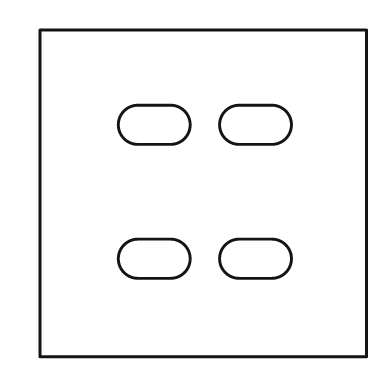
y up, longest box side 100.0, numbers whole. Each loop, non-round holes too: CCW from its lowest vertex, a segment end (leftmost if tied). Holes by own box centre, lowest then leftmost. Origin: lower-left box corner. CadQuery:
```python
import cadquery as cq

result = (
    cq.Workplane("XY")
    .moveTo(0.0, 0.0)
    .lineTo(100.0, 0.0)
    .lineTo(100.0, 100.0)
    .lineTo(0.0, 100.0)
    .close()
    .moveTo(30.0, 24.0)
    .lineTo(40.0, 24.0)
    .threePointArc((46.0, 30.0), (40.0, 36.0))
    .lineTo(30.0, 36.0)
    .threePointArc((24.0, 30.0), (30.0, 24.0))
    .close()
    .moveTo(61.0, 24.0)
    .lineTo(71.0, 24.0)
    .threePointArc((77.0, 30.0), (71.0, 36.0))
    .lineTo(61.0, 36.0)
    .threePointArc((55.0, 30.0), (61.0, 24.0))
    .close()
    .moveTo(30.0, 65.0)
    .lineTo(40.0, 65.0)
    .threePointArc((46.0, 71.0), (40.0, 77.0))
    .lineTo(30.0, 77.0)
    .threePointArc((24.0, 71.0), (30.0, 65.0))
    .close()
    .moveTo(61.0, 65.0)
    .lineTo(71.0, 65.0)
    .threePointArc((77.0, 71.0), (71.0, 77.0))
    .lineTo(61.0, 77.0)
    .threePointArc((55.0, 71.0), (61.0, 65.0))
    .close()
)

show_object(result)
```